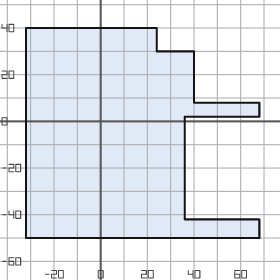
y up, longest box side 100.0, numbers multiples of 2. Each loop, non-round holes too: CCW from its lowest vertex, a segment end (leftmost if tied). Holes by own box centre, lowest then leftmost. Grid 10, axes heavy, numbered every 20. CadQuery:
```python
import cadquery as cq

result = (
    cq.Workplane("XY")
    .moveTo(-32.0, -50.0)
    .lineTo(68.0, -50.0)
    .lineTo(68.0, -42.0)
    .lineTo(36.0, -42.0)
    .lineTo(36.0, 2.0)
    .lineTo(68.0, 2.0)
    .lineTo(68.0, 8.0)
    .lineTo(40.0, 8.0)
    .lineTo(40.0, 30.0)
    .lineTo(24.0, 30.0)
    .lineTo(24.0, 40.0)
    .lineTo(-32.0, 40.0)
    .close()
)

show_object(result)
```